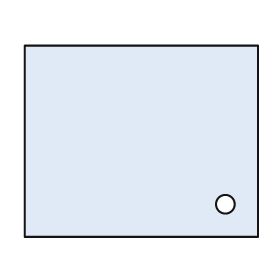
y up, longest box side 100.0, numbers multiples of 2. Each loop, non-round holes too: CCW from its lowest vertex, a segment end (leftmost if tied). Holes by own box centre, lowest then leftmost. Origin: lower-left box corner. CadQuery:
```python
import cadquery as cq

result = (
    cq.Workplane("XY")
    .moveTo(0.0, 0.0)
    .lineTo(100.0, 0.0)
    .lineTo(100.0, 82.0)
    .lineTo(0.0, 82.0)
    .close()
    .moveTo(86.0, 14.0)
    .circle(4.0)
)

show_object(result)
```